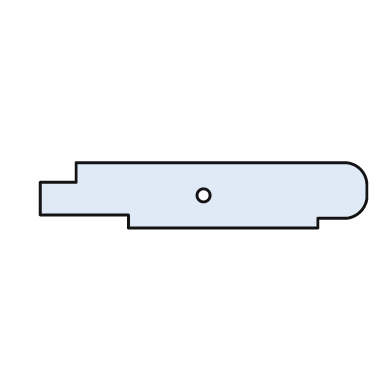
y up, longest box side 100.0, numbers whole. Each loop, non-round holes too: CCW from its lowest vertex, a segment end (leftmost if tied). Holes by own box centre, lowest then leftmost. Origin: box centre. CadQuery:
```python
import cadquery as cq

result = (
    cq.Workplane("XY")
    .moveTo(-23.0, -10.0)
    .lineTo(35.0, -10.0)
    .lineTo(35.0, -7.0)
    .lineTo(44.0, -7.0)
    .threePointArc((48.0, -5.0), (50.0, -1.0))
    .lineTo(50.0, 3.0)
    .threePointArc((48.0, 8.0), (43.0, 10.0))
    .lineTo(-39.0, 10.0)
    .lineTo(-39.0, 4.0)
    .lineTo(-50.0, 4.0)
    .lineTo(-50.0, -6.0)
    .lineTo(-23.0, -6.0)
    .close()
    .moveTo(0.0, 0.0)
    .circle(2.0)
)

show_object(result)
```